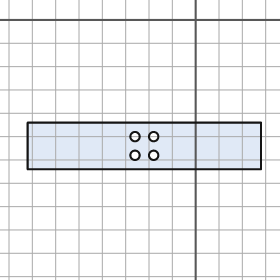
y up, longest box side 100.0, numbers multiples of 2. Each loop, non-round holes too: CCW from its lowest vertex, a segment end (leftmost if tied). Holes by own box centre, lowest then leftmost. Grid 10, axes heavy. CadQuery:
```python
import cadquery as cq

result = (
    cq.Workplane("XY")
    .moveTo(-72.0, -64.0)
    .lineTo(28.0, -64.0)
    .lineTo(28.0, -44.0)
    .lineTo(-72.0, -44.0)
    .close()
    .moveTo(-26.0, -58.0)
    .circle(2.0)
    .moveTo(-18.0, -58.0)
    .circle(2.0)
    .moveTo(-26.0, -50.0)
    .circle(2.0)
    .moveTo(-18.0, -50.0)
    .circle(2.0)
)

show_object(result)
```